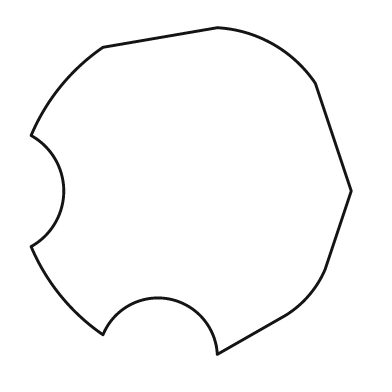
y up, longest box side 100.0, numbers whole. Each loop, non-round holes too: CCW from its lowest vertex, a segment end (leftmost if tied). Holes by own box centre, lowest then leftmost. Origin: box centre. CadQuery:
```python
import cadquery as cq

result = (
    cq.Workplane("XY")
    .moveTo(8.0, -50.0)
    .lineTo(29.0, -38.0)
    .threePointArc((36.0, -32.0), (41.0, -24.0))
    .lineTo(49.0, 0.0)
    .lineTo(38.0, 33.0)
    .threePointArc((25.0, 45.0), (8.0, 50.0))
    .lineTo(-27.0, 44.0)
    .threePointArc((-40.0, 32.0), (-49.0, 17.0))
    .threePointArc((-39.0, 0.0), (-49.0, -17.0))
    .threePointArc((-40.0, -32.0), (-27.0, -44.0))
    .threePointArc((-7.0, -33.0), (8.0, -50.0))
    .close()
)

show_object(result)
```